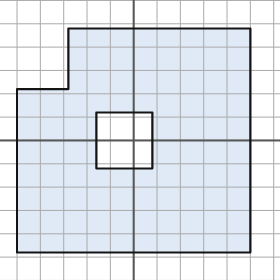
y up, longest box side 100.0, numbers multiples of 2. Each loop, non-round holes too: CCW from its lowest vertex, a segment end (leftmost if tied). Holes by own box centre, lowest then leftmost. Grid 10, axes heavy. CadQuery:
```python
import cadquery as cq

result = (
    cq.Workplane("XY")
    .moveTo(-50.0, -48.0)
    .lineTo(50.0, -48.0)
    .lineTo(50.0, 48.0)
    .lineTo(-28.0, 48.0)
    .lineTo(-28.0, 22.0)
    .lineTo(-50.0, 22.0)
    .close()
    .moveTo(-16.0, -12.0)
    .lineTo(8.0, -12.0)
    .lineTo(8.0, 12.0)
    .lineTo(-16.0, 12.0)
    .close()
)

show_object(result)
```